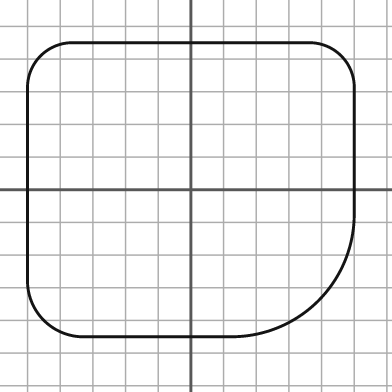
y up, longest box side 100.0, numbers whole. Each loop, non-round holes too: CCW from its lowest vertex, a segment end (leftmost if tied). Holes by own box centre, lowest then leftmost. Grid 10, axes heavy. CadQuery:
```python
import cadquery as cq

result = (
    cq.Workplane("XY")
    .moveTo(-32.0, -45.0)
    .lineTo(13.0, -45.0)
    .threePointArc((39.0, -34.0), (50.0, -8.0))
    .lineTo(50.0, 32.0)
    .threePointArc((46.0, 41.0), (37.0, 45.0))
    .lineTo(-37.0, 45.0)
    .threePointArc((-46.0, 41.0), (-50.0, 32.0))
    .lineTo(-50.0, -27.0)
    .threePointArc((-45.0, -40.0), (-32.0, -45.0))
    .close()
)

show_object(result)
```